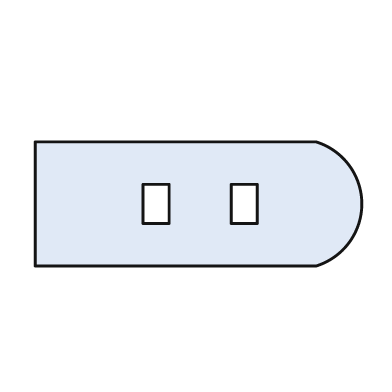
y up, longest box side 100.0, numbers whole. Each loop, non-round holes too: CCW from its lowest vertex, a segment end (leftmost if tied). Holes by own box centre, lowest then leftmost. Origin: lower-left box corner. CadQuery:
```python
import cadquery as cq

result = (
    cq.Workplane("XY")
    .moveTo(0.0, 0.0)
    .lineTo(86.0, 0.0)
    .threePointArc((100.0, 19.0), (86.0, 38.0))
    .lineTo(0.0, 38.0)
    .close()
    .moveTo(33.0, 13.0)
    .lineTo(41.0, 13.0)
    .lineTo(41.0, 25.0)
    .lineTo(33.0, 25.0)
    .close()
    .moveTo(60.0, 13.0)
    .lineTo(68.0, 13.0)
    .lineTo(68.0, 25.0)
    .lineTo(60.0, 25.0)
    .close()
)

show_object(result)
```